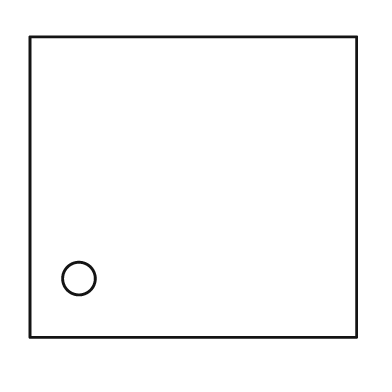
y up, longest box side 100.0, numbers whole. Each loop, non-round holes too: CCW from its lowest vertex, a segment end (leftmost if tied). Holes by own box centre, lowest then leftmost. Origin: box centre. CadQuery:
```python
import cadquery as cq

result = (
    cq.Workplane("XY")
    .moveTo(-50.0, -46.0)
    .lineTo(50.0, -46.0)
    .lineTo(50.0, 46.0)
    .lineTo(-50.0, 46.0)
    .close()
    .moveTo(-35.0, -28.0)
    .circle(5.0)
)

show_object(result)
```